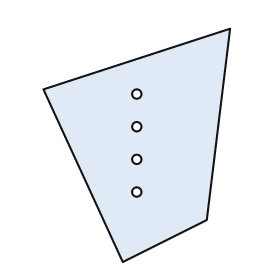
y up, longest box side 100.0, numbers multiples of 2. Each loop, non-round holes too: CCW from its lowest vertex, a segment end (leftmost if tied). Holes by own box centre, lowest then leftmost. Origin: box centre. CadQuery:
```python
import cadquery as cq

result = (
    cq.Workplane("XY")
    .moveTo(-6.0, -50.0)
    .lineTo(30.0, -32.0)
    .lineTo(40.0, 50.0)
    .lineTo(-40.0, 24.0)
    .close()
    .moveTo(0.0, -20.0)
    .circle(2.0)
    .moveTo(0.0, -6.0)
    .circle(2.0)
    .moveTo(0.0, 8.0)
    .circle(2.0)
    .moveTo(0.0, 22.0)
    .circle(2.0)
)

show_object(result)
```